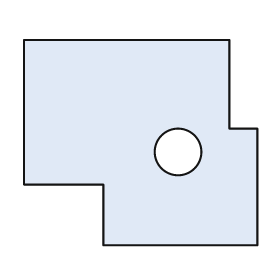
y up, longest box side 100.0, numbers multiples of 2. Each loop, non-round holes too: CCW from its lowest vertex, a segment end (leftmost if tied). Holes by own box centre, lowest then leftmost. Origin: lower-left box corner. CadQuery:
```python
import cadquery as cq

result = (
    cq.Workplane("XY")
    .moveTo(34.0, 0.0)
    .lineTo(100.0, 0.0)
    .lineTo(100.0, 50.0)
    .lineTo(88.0, 50.0)
    .lineTo(88.0, 88.0)
    .lineTo(0.0, 88.0)
    .lineTo(0.0, 26.0)
    .lineTo(34.0, 26.0)
    .close()
    .moveTo(66.0, 40.0)
    .circle(10.0)
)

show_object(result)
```